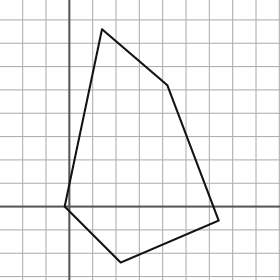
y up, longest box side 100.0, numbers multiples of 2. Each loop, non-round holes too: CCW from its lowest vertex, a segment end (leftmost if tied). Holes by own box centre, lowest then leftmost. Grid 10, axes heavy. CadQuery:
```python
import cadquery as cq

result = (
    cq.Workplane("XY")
    .moveTo(22.0, -24.0)
    .lineTo(64.0, -6.0)
    .lineTo(42.0, 52.0)
    .lineTo(14.0, 76.0)
    .lineTo(-2.0, 0.0)
    .close()
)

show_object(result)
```